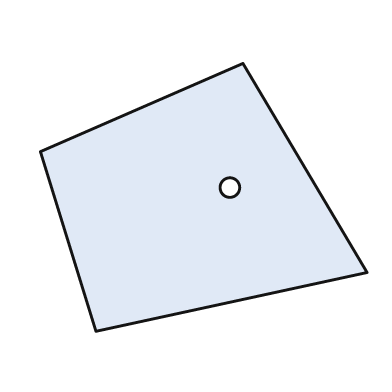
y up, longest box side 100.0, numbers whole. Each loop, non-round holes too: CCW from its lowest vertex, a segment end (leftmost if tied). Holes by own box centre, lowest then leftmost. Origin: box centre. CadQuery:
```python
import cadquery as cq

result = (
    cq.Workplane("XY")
    .moveTo(-33.0, -41.0)
    .lineTo(50.0, -23.0)
    .lineTo(12.0, 41.0)
    .lineTo(-50.0, 14.0)
    .close()
    .moveTo(8.0, 3.0)
    .circle(3.0)
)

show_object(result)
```